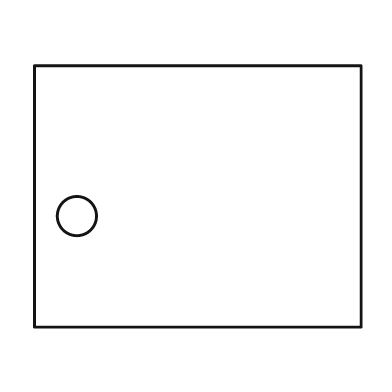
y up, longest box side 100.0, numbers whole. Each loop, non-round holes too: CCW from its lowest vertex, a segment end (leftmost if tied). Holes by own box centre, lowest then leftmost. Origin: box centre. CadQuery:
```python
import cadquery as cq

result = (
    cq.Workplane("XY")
    .moveTo(-50.0, -40.0)
    .lineTo(50.0, -40.0)
    .lineTo(50.0, 40.0)
    .lineTo(-50.0, 40.0)
    .close()
    .moveTo(-37.0, -6.0)
    .circle(6.0)
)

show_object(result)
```